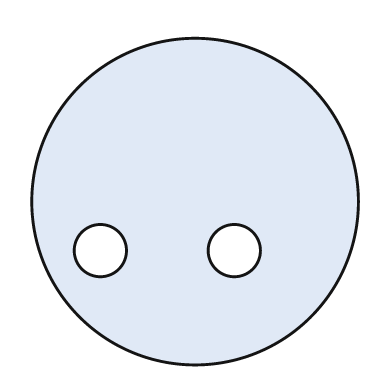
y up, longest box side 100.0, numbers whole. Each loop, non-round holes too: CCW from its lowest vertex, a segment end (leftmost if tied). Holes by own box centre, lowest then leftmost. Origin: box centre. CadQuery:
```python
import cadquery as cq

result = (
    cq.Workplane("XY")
    .moveTo(0.0, 0.0)
    .circle(50.0)
    .moveTo(-29.0, -15.0)
    .circle(8.0)
    .moveTo(12.0, -15.0)
    .circle(8.0)
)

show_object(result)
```